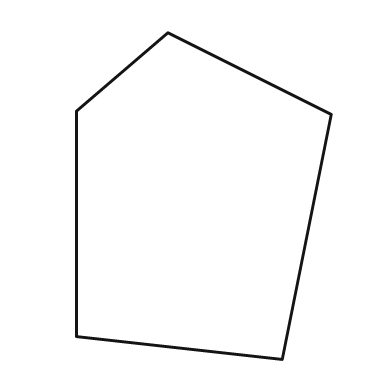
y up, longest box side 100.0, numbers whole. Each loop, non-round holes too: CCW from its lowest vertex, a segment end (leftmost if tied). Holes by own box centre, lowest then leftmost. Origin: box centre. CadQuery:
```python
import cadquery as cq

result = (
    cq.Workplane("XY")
    .moveTo(24.0, -50.0)
    .lineTo(39.0, 25.0)
    .lineTo(-11.0, 50.0)
    .lineTo(-39.0, 26.0)
    .lineTo(-39.0, -43.0)
    .close()
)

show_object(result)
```